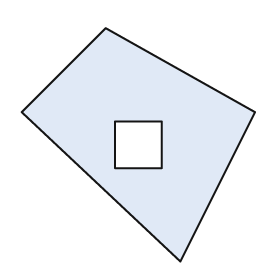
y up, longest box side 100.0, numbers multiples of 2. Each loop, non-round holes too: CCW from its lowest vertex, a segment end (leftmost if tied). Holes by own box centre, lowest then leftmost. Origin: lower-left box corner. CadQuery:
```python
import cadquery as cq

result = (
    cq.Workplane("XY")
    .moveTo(68.0, 0.0)
    .lineTo(100.0, 64.0)
    .lineTo(36.0, 100.0)
    .lineTo(0.0, 64.0)
    .close()
    .moveTo(40.0, 40.0)
    .lineTo(60.0, 40.0)
    .lineTo(60.0, 60.0)
    .lineTo(40.0, 60.0)
    .close()
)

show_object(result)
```